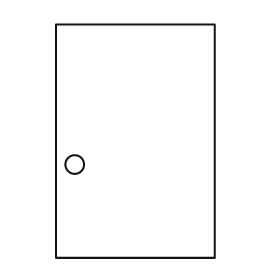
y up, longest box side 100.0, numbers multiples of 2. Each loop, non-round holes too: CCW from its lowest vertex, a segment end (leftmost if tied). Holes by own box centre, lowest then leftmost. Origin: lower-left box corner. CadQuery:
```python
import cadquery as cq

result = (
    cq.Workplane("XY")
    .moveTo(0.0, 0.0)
    .lineTo(68.0, 0.0)
    .lineTo(68.0, 100.0)
    .lineTo(0.0, 100.0)
    .close()
    .moveTo(8.0, 40.0)
    .circle(4.0)
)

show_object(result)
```